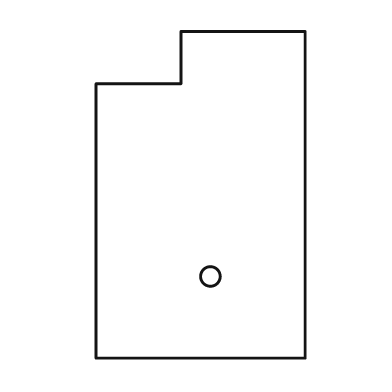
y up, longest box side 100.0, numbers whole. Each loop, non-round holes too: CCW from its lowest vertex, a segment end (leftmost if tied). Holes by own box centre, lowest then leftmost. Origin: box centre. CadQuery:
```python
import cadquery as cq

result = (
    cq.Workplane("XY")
    .moveTo(-32.0, -50.0)
    .lineTo(32.0, -50.0)
    .lineTo(32.0, 50.0)
    .lineTo(-6.0, 50.0)
    .lineTo(-6.0, 34.0)
    .lineTo(-32.0, 34.0)
    .close()
    .moveTo(3.0, -25.0)
    .circle(3.0)
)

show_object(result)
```